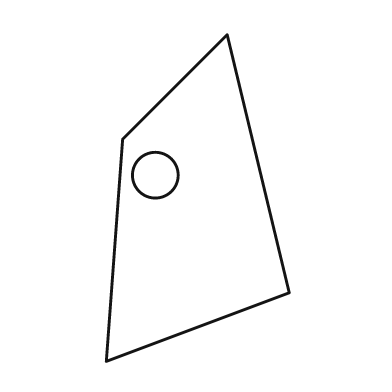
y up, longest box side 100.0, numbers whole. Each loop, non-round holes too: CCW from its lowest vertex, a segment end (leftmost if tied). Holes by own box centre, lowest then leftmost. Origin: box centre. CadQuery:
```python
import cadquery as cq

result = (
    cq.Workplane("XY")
    .moveTo(-28.0, -50.0)
    .lineTo(28.0, -29.0)
    .lineTo(9.0, 50.0)
    .lineTo(-23.0, 18.0)
    .close()
    .moveTo(-13.0, 7.0)
    .circle(7.0)
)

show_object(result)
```